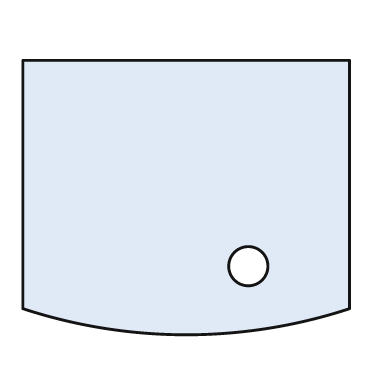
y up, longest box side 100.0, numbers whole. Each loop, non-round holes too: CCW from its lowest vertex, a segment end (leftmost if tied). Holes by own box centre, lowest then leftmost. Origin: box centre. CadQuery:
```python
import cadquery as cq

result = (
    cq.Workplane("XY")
    .moveTo(-50.0, -34.0)
    .threePointArc((0.0, -42.0), (50.0, -34.0))
    .lineTo(50.0, 42.0)
    .lineTo(-50.0, 42.0)
    .close()
    .moveTo(19.0, -21.0)
    .circle(6.0)
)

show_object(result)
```